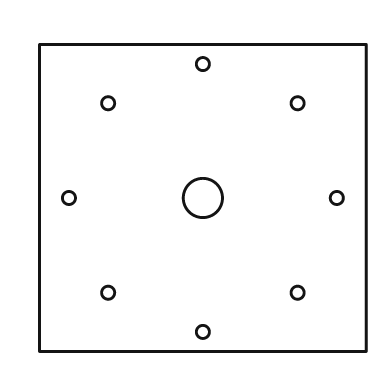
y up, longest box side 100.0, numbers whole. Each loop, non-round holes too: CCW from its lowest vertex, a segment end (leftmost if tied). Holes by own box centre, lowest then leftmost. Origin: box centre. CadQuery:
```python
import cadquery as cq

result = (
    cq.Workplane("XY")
    .moveTo(-50.0, -47.0)
    .lineTo(50.0, -47.0)
    .lineTo(50.0, 47.0)
    .lineTo(-50.0, 47.0)
    .close()
    .moveTo(0.0, -41.0)
    .circle(2.0)
    .moveTo(-29.0, -29.0)
    .circle(2.0)
    .moveTo(29.0, -29.0)
    .circle(2.0)
    .moveTo(-41.0, 0.0)
    .circle(2.0)
    .moveTo(0.0, 0.0)
    .circle(6.0)
    .moveTo(41.0, 0.0)
    .circle(2.0)
    .moveTo(-29.0, 29.0)
    .circle(2.0)
    .moveTo(29.0, 29.0)
    .circle(2.0)
    .moveTo(0.0, 41.0)
    .circle(2.0)
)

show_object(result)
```